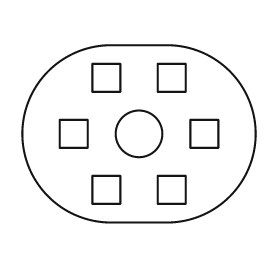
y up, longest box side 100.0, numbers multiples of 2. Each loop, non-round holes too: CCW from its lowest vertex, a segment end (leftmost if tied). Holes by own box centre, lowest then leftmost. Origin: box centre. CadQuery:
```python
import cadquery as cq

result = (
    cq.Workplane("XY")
    .moveTo(-12.0, -38.0)
    .lineTo(12.0, -38.0)
    .threePointArc((50.0, 0.0), (12.0, 38.0))
    .lineTo(-12.0, 38.0)
    .threePointArc((-50.0, 0.0), (-12.0, -38.0))
    .close()
    .moveTo(-20.0, -30.0)
    .lineTo(-8.0, -30.0)
    .lineTo(-8.0, -18.0)
    .lineTo(-20.0, -18.0)
    .close()
    .moveTo(8.0, -30.0)
    .lineTo(20.0, -30.0)
    .lineTo(20.0, -18.0)
    .lineTo(8.0, -18.0)
    .close()
    .moveTo(-34.0, -6.0)
    .lineTo(-22.0, -6.0)
    .lineTo(-22.0, 6.0)
    .lineTo(-34.0, 6.0)
    .close()
    .moveTo(0.0, 0.0)
    .circle(10.0)
    .moveTo(22.0, -6.0)
    .lineTo(34.0, -6.0)
    .lineTo(34.0, 6.0)
    .lineTo(22.0, 6.0)
    .close()
    .moveTo(-20.0, 18.0)
    .lineTo(-8.0, 18.0)
    .lineTo(-8.0, 30.0)
    .lineTo(-20.0, 30.0)
    .close()
    .moveTo(8.0, 18.0)
    .lineTo(20.0, 18.0)
    .lineTo(20.0, 30.0)
    .lineTo(8.0, 30.0)
    .close()
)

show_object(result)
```